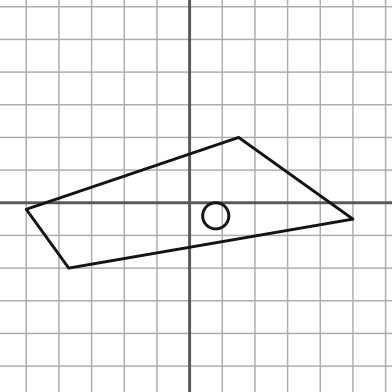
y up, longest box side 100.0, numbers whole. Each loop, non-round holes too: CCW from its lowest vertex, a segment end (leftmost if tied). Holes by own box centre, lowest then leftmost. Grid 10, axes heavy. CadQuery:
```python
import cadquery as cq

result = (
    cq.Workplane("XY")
    .moveTo(-37.0, -20.0)
    .lineTo(50.0, -5.0)
    .lineTo(15.0, 20.0)
    .lineTo(-50.0, -2.0)
    .close()
    .moveTo(8.0, -4.0)
    .circle(4.0)
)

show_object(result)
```